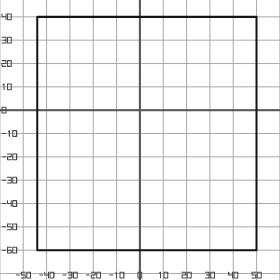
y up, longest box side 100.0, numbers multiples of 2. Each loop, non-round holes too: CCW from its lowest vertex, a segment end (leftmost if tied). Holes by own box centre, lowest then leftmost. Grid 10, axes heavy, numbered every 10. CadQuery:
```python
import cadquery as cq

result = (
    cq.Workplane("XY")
    .moveTo(-44.0, -60.0)
    .lineTo(50.0, -60.0)
    .lineTo(50.0, 40.0)
    .lineTo(-44.0, 40.0)
    .close()
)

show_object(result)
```